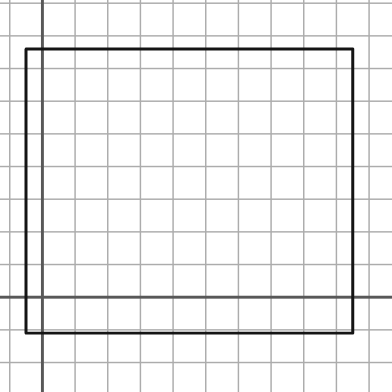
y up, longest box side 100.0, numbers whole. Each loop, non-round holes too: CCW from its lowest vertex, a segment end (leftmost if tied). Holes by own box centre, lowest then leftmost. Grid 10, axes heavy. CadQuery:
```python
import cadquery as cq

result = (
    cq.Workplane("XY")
    .moveTo(-5.0, -11.0)
    .lineTo(95.0, -11.0)
    .lineTo(95.0, 76.0)
    .lineTo(-5.0, 76.0)
    .close()
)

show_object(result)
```